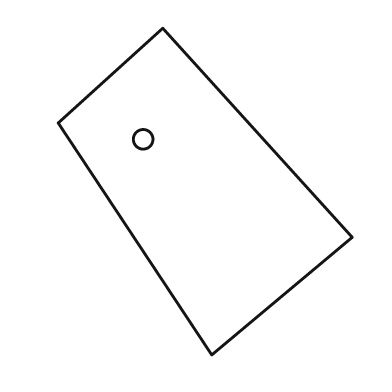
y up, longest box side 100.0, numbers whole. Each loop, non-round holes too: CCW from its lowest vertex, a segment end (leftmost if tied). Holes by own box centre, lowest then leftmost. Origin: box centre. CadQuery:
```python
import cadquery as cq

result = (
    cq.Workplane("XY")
    .moveTo(2.0, -50.0)
    .lineTo(45.0, -14.0)
    .lineTo(-13.0, 50.0)
    .lineTo(-45.0, 21.0)
    .close()
    .moveTo(-19.0, 16.0)
    .circle(3.0)
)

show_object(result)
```